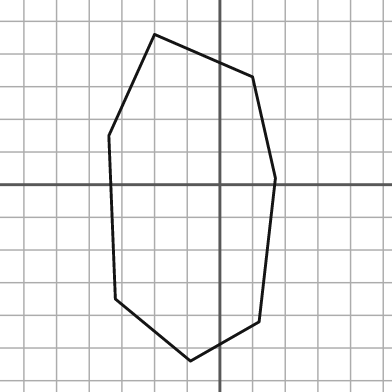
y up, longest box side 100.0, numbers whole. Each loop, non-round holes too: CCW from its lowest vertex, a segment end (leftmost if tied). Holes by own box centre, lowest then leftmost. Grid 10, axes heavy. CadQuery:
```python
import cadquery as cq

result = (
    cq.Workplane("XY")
    .moveTo(-9.0, -54.0)
    .lineTo(12.0, -42.0)
    .lineTo(17.0, 2.0)
    .lineTo(10.0, 33.0)
    .lineTo(-20.0, 46.0)
    .lineTo(-34.0, 15.0)
    .lineTo(-32.0, -35.0)
    .close()
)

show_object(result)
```